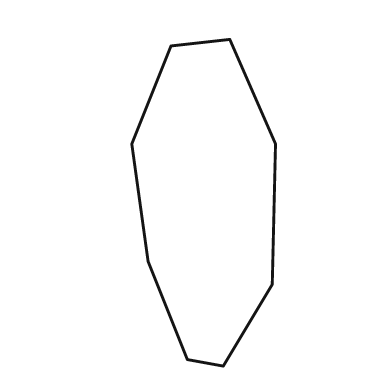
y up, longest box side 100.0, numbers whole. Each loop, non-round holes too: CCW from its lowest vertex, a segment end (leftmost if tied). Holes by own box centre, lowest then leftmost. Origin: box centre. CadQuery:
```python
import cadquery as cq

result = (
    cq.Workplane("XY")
    .moveTo(6.0, -50.0)
    .lineTo(21.0, -25.0)
    .lineTo(22.0, 18.0)
    .lineTo(8.0, 50.0)
    .lineTo(-10.0, 48.0)
    .lineTo(-22.0, 18.0)
    .lineTo(-17.0, -18.0)
    .lineTo(-5.0, -48.0)
    .close()
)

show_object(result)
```